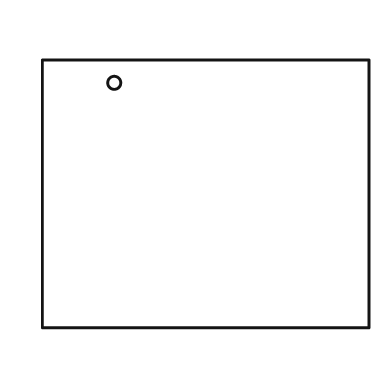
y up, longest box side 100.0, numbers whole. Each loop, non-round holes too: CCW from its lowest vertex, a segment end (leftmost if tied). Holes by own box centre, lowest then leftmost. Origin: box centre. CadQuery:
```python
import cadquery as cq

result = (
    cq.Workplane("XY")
    .moveTo(-50.0, -41.0)
    .lineTo(50.0, -41.0)
    .lineTo(50.0, 41.0)
    .lineTo(-50.0, 41.0)
    .close()
    .moveTo(-28.0, 34.0)
    .circle(2.0)
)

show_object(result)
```